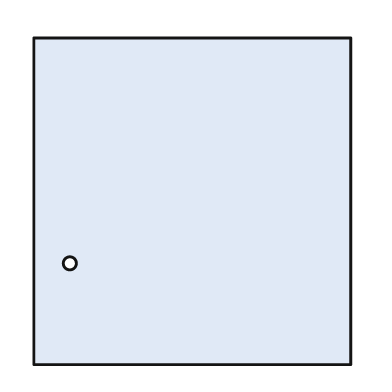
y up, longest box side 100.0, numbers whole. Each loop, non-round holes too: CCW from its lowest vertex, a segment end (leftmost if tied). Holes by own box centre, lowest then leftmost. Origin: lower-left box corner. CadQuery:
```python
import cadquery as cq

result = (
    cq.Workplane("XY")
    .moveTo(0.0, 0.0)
    .lineTo(97.0, 0.0)
    .lineTo(97.0, 100.0)
    .lineTo(0.0, 100.0)
    .close()
    .moveTo(11.0, 31.0)
    .circle(2.0)
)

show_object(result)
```